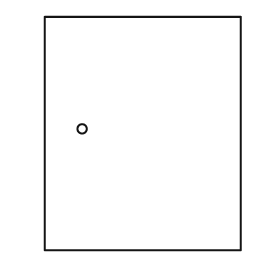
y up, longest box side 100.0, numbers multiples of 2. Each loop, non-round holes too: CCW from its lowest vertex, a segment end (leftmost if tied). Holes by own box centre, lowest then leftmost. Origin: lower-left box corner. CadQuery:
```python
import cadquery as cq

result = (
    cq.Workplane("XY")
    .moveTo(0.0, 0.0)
    .lineTo(84.0, 0.0)
    .lineTo(84.0, 100.0)
    .lineTo(0.0, 100.0)
    .close()
    .moveTo(16.0, 52.0)
    .circle(2.0)
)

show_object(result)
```